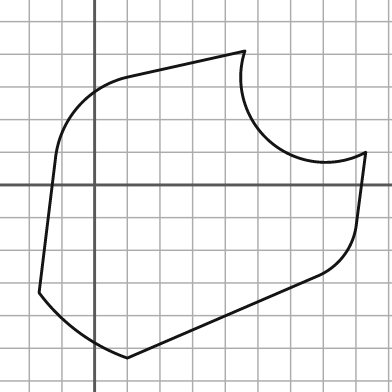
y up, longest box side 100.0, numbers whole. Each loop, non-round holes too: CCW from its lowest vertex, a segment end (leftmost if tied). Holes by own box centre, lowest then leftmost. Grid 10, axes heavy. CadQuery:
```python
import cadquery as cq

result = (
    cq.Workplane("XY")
    .moveTo(10.0, -53.0)
    .lineTo(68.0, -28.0)
    .threePointArc((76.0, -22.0), (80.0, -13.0))
    .lineTo(83.0, 10.0)
    .threePointArc((54.0, 13.0), (46.0, 41.0))
    .lineTo(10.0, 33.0)
    .threePointArc((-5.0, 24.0), (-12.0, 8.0))
    .lineTo(-17.0, -33.0)
    .threePointArc((-5.0, -45.0), (10.0, -53.0))
    .close()
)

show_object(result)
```